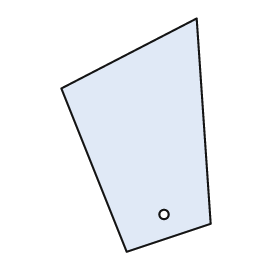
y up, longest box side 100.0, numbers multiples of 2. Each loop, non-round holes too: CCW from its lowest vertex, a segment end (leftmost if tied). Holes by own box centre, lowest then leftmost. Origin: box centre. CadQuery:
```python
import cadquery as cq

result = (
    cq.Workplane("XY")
    .moveTo(-4.0, -50.0)
    .lineTo(32.0, -38.0)
    .lineTo(26.0, 50.0)
    .lineTo(-32.0, 20.0)
    .close()
    .moveTo(12.0, -34.0)
    .circle(2.0)
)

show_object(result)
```